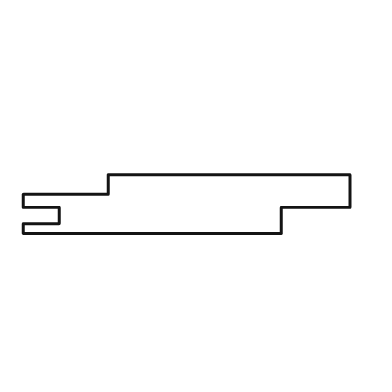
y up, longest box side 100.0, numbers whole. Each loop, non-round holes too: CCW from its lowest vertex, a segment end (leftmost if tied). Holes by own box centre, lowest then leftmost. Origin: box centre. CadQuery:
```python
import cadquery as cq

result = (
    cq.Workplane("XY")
    .moveTo(-50.0, -9.0)
    .lineTo(29.0, -9.0)
    .lineTo(29.0, -1.0)
    .lineTo(50.0, -1.0)
    .lineTo(50.0, 9.0)
    .lineTo(-24.0, 9.0)
    .lineTo(-24.0, 3.0)
    .lineTo(-50.0, 3.0)
    .lineTo(-50.0, -1.0)
    .lineTo(-39.0, -1.0)
    .lineTo(-39.0, -6.0)
    .lineTo(-50.0, -6.0)
    .close()
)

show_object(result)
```